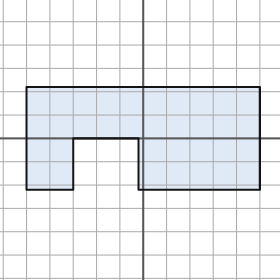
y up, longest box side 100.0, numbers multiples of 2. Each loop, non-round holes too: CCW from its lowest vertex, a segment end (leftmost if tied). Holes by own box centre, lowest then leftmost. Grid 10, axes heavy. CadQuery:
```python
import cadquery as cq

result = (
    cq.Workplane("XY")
    .moveTo(-50.0, -22.0)
    .lineTo(-30.0, -22.0)
    .lineTo(-30.0, 0.0)
    .lineTo(-2.0, 0.0)
    .lineTo(-2.0, -22.0)
    .lineTo(50.0, -22.0)
    .lineTo(50.0, 22.0)
    .lineTo(-50.0, 22.0)
    .close()
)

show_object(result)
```